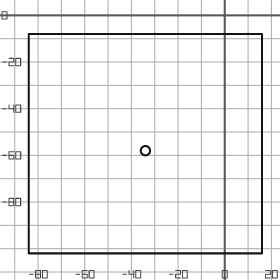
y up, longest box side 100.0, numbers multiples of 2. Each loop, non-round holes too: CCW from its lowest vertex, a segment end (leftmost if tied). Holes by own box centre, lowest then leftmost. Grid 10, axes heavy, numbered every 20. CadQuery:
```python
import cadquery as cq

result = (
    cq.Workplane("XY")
    .moveTo(-84.0, -102.0)
    .lineTo(16.0, -102.0)
    .lineTo(16.0, -8.0)
    .lineTo(-84.0, -8.0)
    .close()
    .moveTo(-34.0, -58.0)
    .circle(2.0)
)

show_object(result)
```